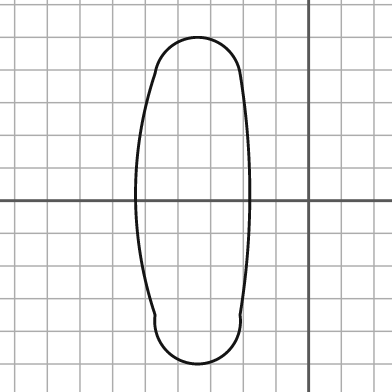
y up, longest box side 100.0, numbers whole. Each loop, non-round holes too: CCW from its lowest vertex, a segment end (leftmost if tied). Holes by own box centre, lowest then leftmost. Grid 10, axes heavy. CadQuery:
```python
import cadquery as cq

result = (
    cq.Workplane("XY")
    .moveTo(-47.0, -35.0)
    .threePointArc((-34.0, -50.0), (-21.0, -35.0))
    .threePointArc((-18.0, 2.0), (-21.0, 39.0))
    .threePointArc((-34.0, 50.0), (-47.0, 39.0))
    .threePointArc((-53.0, 2.0), (-47.0, -35.0))
    .close()
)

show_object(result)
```